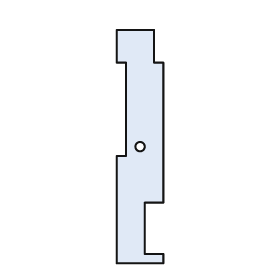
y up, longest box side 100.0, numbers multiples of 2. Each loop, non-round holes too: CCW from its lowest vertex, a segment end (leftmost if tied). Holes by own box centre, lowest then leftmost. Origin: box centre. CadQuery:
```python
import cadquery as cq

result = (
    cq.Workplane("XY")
    .moveTo(-10.0, -50.0)
    .lineTo(10.0, -50.0)
    .lineTo(10.0, -46.0)
    .lineTo(2.0, -46.0)
    .lineTo(2.0, -24.0)
    .lineTo(10.0, -24.0)
    .lineTo(10.0, 36.0)
    .lineTo(6.0, 36.0)
    .lineTo(6.0, 50.0)
    .lineTo(-10.0, 50.0)
    .lineTo(-10.0, 36.0)
    .lineTo(-6.0, 36.0)
    .lineTo(-6.0, -4.0)
    .lineTo(-10.0, -4.0)
    .close()
    .moveTo(0.0, 0.0)
    .circle(2.0)
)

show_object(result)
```